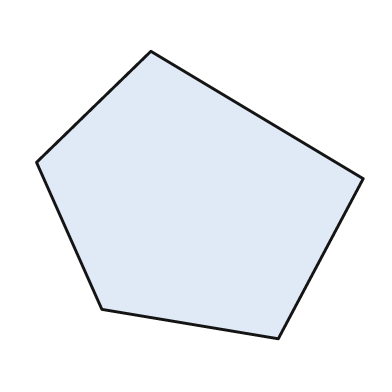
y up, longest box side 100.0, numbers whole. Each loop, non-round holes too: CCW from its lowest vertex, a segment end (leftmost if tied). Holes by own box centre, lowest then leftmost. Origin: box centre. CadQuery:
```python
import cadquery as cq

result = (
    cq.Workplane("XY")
    .moveTo(24.0, -44.0)
    .lineTo(50.0, 5.0)
    .lineTo(-15.0, 44.0)
    .lineTo(-50.0, 10.0)
    .lineTo(-30.0, -35.0)
    .close()
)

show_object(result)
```